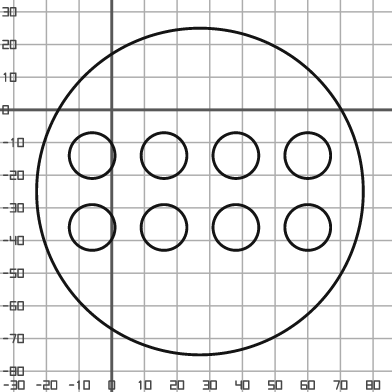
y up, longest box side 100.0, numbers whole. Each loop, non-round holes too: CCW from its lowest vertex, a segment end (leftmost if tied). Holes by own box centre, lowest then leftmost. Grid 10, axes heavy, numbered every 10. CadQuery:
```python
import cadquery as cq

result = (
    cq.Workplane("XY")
    .moveTo(27.0, -25.0)
    .circle(50.0)
    .moveTo(-6.0, -36.0)
    .circle(7.0)
    .moveTo(16.0, -36.0)
    .circle(7.0)
    .moveTo(38.0, -36.0)
    .circle(7.0)
    .moveTo(60.0, -36.0)
    .circle(7.0)
    .moveTo(-6.0, -14.0)
    .circle(7.0)
    .moveTo(16.0, -14.0)
    .circle(7.0)
    .moveTo(38.0, -14.0)
    .circle(7.0)
    .moveTo(60.0, -14.0)
    .circle(7.0)
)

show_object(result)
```